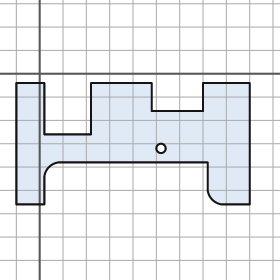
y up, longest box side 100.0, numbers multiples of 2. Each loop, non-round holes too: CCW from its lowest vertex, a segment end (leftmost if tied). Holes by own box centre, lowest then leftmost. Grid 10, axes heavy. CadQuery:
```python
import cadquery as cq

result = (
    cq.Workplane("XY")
    .moveTo(-10.0, -56.0)
    .lineTo(2.0, -56.0)
    .lineTo(2.0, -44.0)
    .threePointArc((4.0, -40.0), (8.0, -38.0))
    .lineTo(72.0, -38.0)
    .lineTo(72.0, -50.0)
    .threePointArc((74.0, -54.0), (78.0, -56.0))
    .lineTo(90.0, -56.0)
    .lineTo(90.0, -4.0)
    .lineTo(70.0, -4.0)
    .lineTo(70.0, -16.0)
    .lineTo(48.0, -16.0)
    .lineTo(48.0, -4.0)
    .lineTo(22.0, -4.0)
    .lineTo(22.0, -26.0)
    .lineTo(2.0, -26.0)
    .lineTo(2.0, -4.0)
    .lineTo(-10.0, -4.0)
    .close()
    .moveTo(52.0, -32.0)
    .circle(2.0)
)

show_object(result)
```